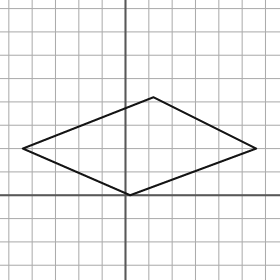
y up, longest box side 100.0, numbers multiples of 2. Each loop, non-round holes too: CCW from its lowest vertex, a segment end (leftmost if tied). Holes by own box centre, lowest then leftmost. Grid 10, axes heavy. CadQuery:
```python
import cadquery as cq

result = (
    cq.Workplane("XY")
    .moveTo(2.0, 0.0)
    .lineTo(56.0, 20.0)
    .lineTo(12.0, 42.0)
    .lineTo(-44.0, 20.0)
    .close()
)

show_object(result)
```